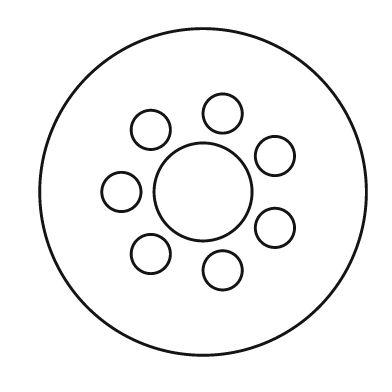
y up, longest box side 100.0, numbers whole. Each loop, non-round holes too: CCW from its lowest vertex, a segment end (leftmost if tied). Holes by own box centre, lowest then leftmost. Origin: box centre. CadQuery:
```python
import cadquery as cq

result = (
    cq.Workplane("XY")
    .moveTo(0.0, 0.0)
    .circle(50.0)
    .moveTo(6.0, -24.0)
    .circle(6.0)
    .moveTo(-16.0, -19.0)
    .circle(6.0)
    .moveTo(22.0, -11.0)
    .circle(6.0)
    .moveTo(-25.0, 0.0)
    .circle(6.0)
    .moveTo(0.0, 0.0)
    .circle(15.0)
    .moveTo(22.0, 11.0)
    .circle(6.0)
    .moveTo(-16.0, 19.0)
    .circle(6.0)
    .moveTo(6.0, 24.0)
    .circle(6.0)
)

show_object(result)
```